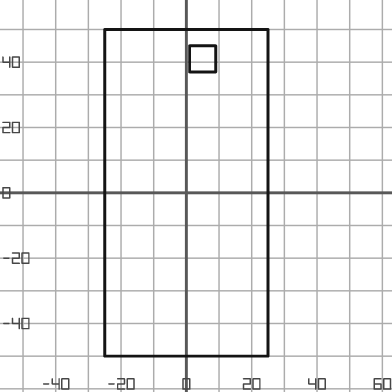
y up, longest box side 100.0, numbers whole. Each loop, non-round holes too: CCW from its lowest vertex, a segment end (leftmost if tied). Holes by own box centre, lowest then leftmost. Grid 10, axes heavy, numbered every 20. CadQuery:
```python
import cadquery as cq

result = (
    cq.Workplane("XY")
    .moveTo(-25.0, -50.0)
    .lineTo(25.0, -50.0)
    .lineTo(25.0, 50.0)
    .lineTo(-25.0, 50.0)
    .close()
    .moveTo(1.0, 37.0)
    .lineTo(9.0, 37.0)
    .lineTo(9.0, 45.0)
    .lineTo(1.0, 45.0)
    .close()
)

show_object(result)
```